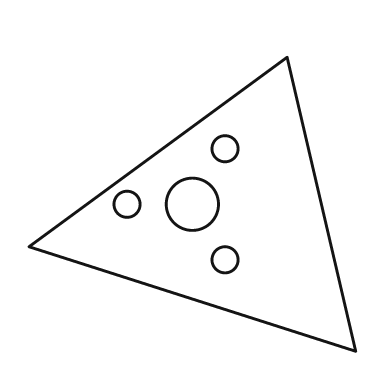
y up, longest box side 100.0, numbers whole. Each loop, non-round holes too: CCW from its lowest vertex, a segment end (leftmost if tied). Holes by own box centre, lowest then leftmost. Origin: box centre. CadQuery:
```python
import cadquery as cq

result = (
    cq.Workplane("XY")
    .moveTo(50.0, -45.0)
    .lineTo(29.0, 45.0)
    .lineTo(-50.0, -13.0)
    .close()
    .moveTo(10.0, -17.0)
    .circle(4.0)
    .moveTo(-20.0, 0.0)
    .circle(4.0)
    .moveTo(0.0, 0.0)
    .circle(8.0)
    .moveTo(10.0, 17.0)
    .circle(4.0)
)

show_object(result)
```